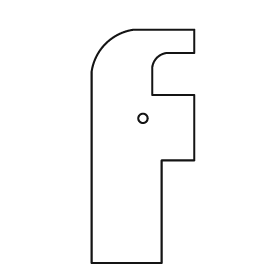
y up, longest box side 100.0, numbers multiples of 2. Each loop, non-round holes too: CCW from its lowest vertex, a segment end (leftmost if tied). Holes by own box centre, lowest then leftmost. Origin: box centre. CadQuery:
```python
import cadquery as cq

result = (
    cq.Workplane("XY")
    .moveTo(-22.0, -50.0)
    .lineTo(8.0, -50.0)
    .lineTo(8.0, -6.0)
    .lineTo(22.0, -6.0)
    .lineTo(22.0, 22.0)
    .lineTo(4.0, 22.0)
    .lineTo(4.0, 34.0)
    .threePointArc((6.0, 38.0), (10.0, 40.0))
    .lineTo(22.0, 40.0)
    .lineTo(22.0, 50.0)
    .lineTo(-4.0, 50.0)
    .threePointArc((-16.0, 44.0), (-22.0, 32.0))
    .close()
    .moveTo(0.0, 12.0)
    .circle(2.0)
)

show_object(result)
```